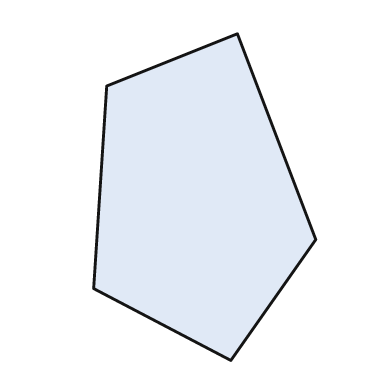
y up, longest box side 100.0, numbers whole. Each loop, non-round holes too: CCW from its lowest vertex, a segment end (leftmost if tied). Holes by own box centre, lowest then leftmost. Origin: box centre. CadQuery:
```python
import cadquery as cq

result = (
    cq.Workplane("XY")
    .moveTo(8.0, -50.0)
    .lineTo(34.0, -13.0)
    .lineTo(10.0, 50.0)
    .lineTo(-30.0, 34.0)
    .lineTo(-34.0, -28.0)
    .close()
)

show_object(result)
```